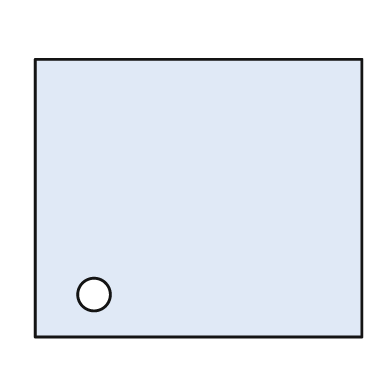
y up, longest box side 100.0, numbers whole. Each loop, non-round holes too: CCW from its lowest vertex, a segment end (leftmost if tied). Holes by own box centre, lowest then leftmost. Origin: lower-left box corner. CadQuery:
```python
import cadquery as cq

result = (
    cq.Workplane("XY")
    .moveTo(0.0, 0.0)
    .lineTo(100.0, 0.0)
    .lineTo(100.0, 85.0)
    .lineTo(0.0, 85.0)
    .close()
    .moveTo(18.0, 13.0)
    .circle(5.0)
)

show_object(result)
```